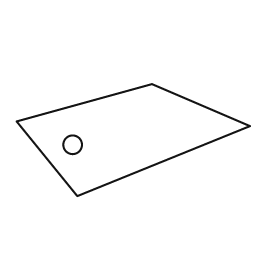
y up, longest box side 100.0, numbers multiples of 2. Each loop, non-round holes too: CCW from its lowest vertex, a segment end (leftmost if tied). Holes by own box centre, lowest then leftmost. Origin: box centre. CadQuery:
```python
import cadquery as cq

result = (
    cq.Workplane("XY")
    .moveTo(-24.0, -24.0)
    .lineTo(50.0, 6.0)
    .lineTo(8.0, 24.0)
    .lineTo(-50.0, 8.0)
    .close()
    .moveTo(-26.0, -2.0)
    .circle(4.0)
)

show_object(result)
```